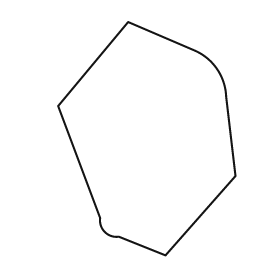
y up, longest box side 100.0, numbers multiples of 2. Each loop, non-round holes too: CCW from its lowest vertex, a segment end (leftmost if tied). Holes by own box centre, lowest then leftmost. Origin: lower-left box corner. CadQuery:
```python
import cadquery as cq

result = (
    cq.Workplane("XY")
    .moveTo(46.0, 0.0)
    .lineTo(76.0, 34.0)
    .lineTo(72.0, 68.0)
    .threePointArc((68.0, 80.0), (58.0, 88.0))
    .lineTo(30.0, 100.0)
    .lineTo(0.0, 64.0)
    .lineTo(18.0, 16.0)
    .threePointArc((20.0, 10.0), (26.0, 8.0))
    .close()
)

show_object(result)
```